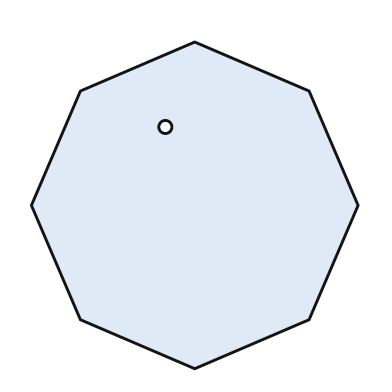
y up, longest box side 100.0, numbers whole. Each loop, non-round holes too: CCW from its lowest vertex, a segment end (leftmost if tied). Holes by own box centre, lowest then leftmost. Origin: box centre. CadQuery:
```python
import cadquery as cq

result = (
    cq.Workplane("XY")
    .moveTo(0.0, -50.0)
    .lineTo(35.0, -35.0)
    .lineTo(50.0, 0.0)
    .lineTo(35.0, 35.0)
    .lineTo(0.0, 50.0)
    .lineTo(-35.0, 35.0)
    .lineTo(-50.0, 0.0)
    .lineTo(-35.0, -35.0)
    .close()
    .moveTo(-9.0, 24.0)
    .circle(2.0)
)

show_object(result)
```